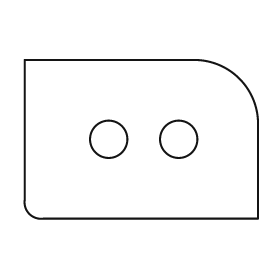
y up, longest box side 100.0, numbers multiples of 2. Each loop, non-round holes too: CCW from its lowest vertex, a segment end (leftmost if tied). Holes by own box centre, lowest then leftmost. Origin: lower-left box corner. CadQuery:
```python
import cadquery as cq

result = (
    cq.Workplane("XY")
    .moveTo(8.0, 0.0)
    .lineTo(100.0, 0.0)
    .lineTo(100.0, 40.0)
    .threePointArc((92.0, 60.0), (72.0, 68.0))
    .lineTo(0.0, 68.0)
    .lineTo(0.0, 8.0)
    .threePointArc((2.0, 2.0), (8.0, 0.0))
    .close()
    .moveTo(36.0, 34.0)
    .circle(8.0)
    .moveTo(66.0, 34.0)
    .circle(8.0)
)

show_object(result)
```